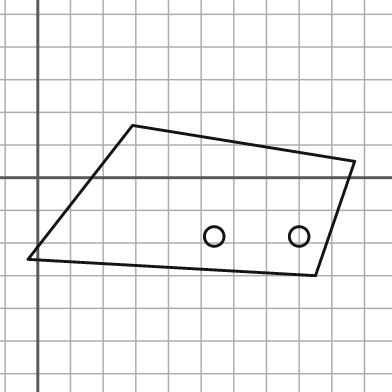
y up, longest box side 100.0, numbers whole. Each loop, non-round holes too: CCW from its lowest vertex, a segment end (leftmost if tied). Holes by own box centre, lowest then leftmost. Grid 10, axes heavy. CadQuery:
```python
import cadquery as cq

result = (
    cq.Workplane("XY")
    .moveTo(85.0, -30.0)
    .lineTo(97.0, 5.0)
    .lineTo(29.0, 16.0)
    .lineTo(-3.0, -25.0)
    .close()
    .moveTo(54.0, -18.0)
    .circle(3.0)
    .moveTo(80.0, -18.0)
    .circle(3.0)
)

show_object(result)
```